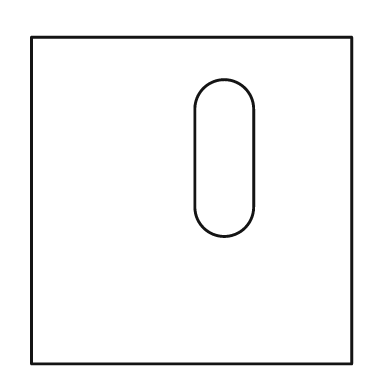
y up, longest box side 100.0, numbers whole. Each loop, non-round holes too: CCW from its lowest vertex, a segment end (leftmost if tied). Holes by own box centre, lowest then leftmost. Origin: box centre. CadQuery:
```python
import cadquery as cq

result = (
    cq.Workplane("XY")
    .moveTo(-49.0, -50.0)
    .lineTo(49.0, -50.0)
    .lineTo(49.0, 50.0)
    .lineTo(-49.0, 50.0)
    .close()
    .moveTo(1.0, -2.0)
    .threePointArc((10.0, -11.0), (19.0, -2.0))
    .lineTo(19.0, 28.0)
    .threePointArc((10.0, 37.0), (1.0, 28.0))
    .close()
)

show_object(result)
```